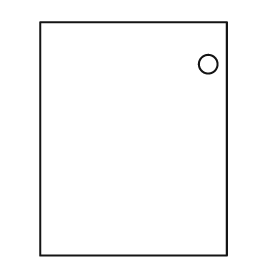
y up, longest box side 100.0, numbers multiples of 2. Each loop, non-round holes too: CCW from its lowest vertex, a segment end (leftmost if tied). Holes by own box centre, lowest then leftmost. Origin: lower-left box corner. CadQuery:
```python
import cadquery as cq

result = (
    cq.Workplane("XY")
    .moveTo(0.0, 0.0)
    .lineTo(80.0, 0.0)
    .lineTo(80.0, 100.0)
    .lineTo(0.0, 100.0)
    .close()
    .moveTo(72.0, 82.0)
    .circle(4.0)
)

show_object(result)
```